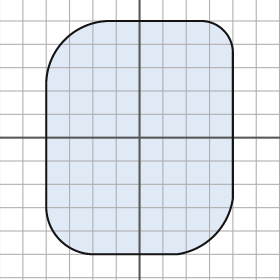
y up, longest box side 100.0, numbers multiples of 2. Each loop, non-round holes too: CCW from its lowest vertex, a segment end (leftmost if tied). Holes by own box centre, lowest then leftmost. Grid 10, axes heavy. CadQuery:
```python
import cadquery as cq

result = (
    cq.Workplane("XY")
    .moveTo(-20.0, -50.0)
    .lineTo(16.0, -50.0)
    .threePointArc((32.0, -42.0), (40.0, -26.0))
    .lineTo(40.0, 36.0)
    .threePointArc((36.0, 46.0), (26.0, 50.0))
    .lineTo(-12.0, 50.0)
    .threePointArc((-32.0, 42.0), (-40.0, 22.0))
    .lineTo(-40.0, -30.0)
    .threePointArc((-34.0, -44.0), (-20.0, -50.0))
    .close()
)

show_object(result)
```